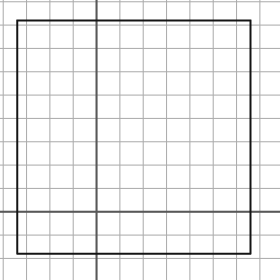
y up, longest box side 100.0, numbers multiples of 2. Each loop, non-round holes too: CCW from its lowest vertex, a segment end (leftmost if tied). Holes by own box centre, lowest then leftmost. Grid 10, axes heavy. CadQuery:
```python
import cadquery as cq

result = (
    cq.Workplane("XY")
    .moveTo(-34.0, -18.0)
    .lineTo(66.0, -18.0)
    .lineTo(66.0, 82.0)
    .lineTo(-34.0, 82.0)
    .close()
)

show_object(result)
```